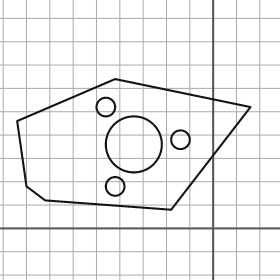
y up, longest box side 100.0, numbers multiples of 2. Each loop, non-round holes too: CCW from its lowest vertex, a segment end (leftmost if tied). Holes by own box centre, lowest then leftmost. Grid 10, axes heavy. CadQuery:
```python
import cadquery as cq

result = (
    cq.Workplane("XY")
    .moveTo(-18.0, 8.0)
    .lineTo(16.0, 52.0)
    .lineTo(-42.0, 64.0)
    .lineTo(-84.0, 46.0)
    .lineTo(-80.0, 18.0)
    .lineTo(-72.0, 12.0)
    .close()
    .moveTo(-42.0, 18.0)
    .circle(4.0)
    .moveTo(-34.0, 36.0)
    .circle(12.0)
    .moveTo(-14.0, 38.0)
    .circle(4.0)
    .moveTo(-46.0, 52.0)
    .circle(4.0)
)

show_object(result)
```